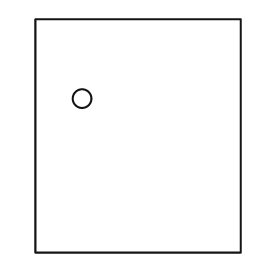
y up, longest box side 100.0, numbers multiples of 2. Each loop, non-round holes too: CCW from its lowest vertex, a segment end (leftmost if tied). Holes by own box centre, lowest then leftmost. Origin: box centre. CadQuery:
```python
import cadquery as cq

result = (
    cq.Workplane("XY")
    .moveTo(-44.0, -50.0)
    .lineTo(44.0, -50.0)
    .lineTo(44.0, 50.0)
    .lineTo(-44.0, 50.0)
    .close()
    .moveTo(-24.0, 16.0)
    .circle(4.0)
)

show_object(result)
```